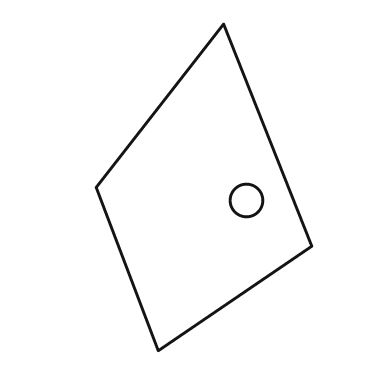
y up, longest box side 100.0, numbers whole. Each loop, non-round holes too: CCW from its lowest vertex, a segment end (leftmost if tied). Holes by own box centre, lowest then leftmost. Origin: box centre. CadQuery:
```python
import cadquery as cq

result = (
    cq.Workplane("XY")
    .moveTo(-14.0, -50.0)
    .lineTo(33.0, -18.0)
    .lineTo(6.0, 50.0)
    .lineTo(-33.0, 0.0)
    .close()
    .moveTo(13.0, -4.0)
    .circle(5.0)
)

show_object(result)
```